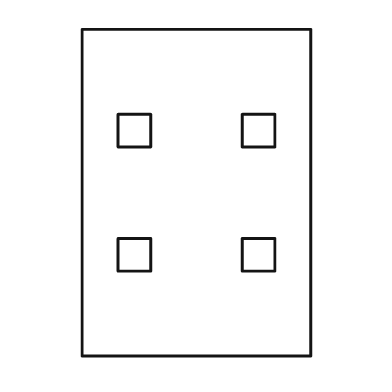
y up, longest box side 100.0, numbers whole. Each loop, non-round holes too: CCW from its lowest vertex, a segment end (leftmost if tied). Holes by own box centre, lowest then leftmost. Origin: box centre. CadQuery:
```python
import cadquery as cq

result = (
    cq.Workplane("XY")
    .moveTo(-35.0, -50.0)
    .lineTo(35.0, -50.0)
    .lineTo(35.0, 50.0)
    .lineTo(-35.0, 50.0)
    .close()
    .moveTo(-24.0, -24.0)
    .lineTo(-14.0, -24.0)
    .lineTo(-14.0, -14.0)
    .lineTo(-24.0, -14.0)
    .close()
    .moveTo(14.0, -24.0)
    .lineTo(24.0, -24.0)
    .lineTo(24.0, -14.0)
    .lineTo(14.0, -14.0)
    .close()
    .moveTo(-24.0, 14.0)
    .lineTo(-14.0, 14.0)
    .lineTo(-14.0, 24.0)
    .lineTo(-24.0, 24.0)
    .close()
    .moveTo(14.0, 14.0)
    .lineTo(24.0, 14.0)
    .lineTo(24.0, 24.0)
    .lineTo(14.0, 24.0)
    .close()
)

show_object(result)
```